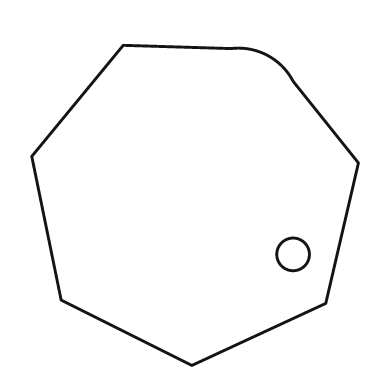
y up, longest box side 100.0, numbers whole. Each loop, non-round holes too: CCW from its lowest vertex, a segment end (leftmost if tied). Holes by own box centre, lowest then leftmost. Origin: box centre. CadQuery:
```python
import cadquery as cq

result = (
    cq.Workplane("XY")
    .moveTo(-1.0, -49.0)
    .lineTo(40.0, -30.0)
    .lineTo(50.0, 13.0)
    .lineTo(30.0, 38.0)
    .threePointArc((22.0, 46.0), (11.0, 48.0))
    .lineTo(-22.0, 49.0)
    .lineTo(-50.0, 15.0)
    .lineTo(-41.0, -29.0)
    .close()
    .moveTo(30.0, -15.0)
    .circle(5.0)
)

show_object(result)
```